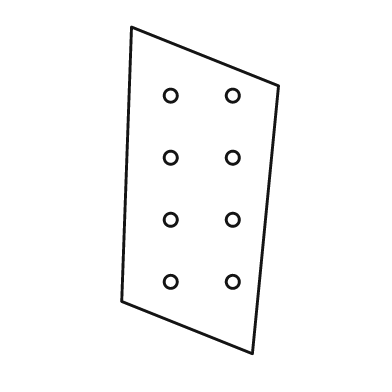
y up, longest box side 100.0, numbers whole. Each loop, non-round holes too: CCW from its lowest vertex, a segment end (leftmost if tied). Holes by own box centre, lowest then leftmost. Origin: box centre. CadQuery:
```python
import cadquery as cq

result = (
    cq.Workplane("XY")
    .moveTo(16.0, -50.0)
    .lineTo(24.0, 32.0)
    .lineTo(-21.0, 50.0)
    .lineTo(-24.0, -34.0)
    .close()
    .moveTo(-9.0, -28.0)
    .circle(2.0)
    .moveTo(10.0, -28.0)
    .circle(2.0)
    .moveTo(-9.0, -9.0)
    .circle(2.0)
    .moveTo(10.0, -9.0)
    .circle(2.0)
    .moveTo(-9.0, 10.0)
    .circle(2.0)
    .moveTo(10.0, 10.0)
    .circle(2.0)
    .moveTo(-9.0, 29.0)
    .circle(2.0)
    .moveTo(10.0, 29.0)
    .circle(2.0)
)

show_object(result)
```